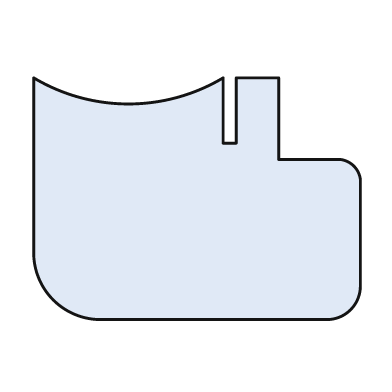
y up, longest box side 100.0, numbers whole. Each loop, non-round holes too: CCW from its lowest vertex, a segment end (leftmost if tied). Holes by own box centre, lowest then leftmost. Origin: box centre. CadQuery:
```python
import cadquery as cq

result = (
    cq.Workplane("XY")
    .moveTo(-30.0, -37.0)
    .lineTo(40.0, -37.0)
    .threePointArc((47.0, -34.0), (50.0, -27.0))
    .lineTo(50.0, 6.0)
    .threePointArc((48.0, 10.0), (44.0, 12.0))
    .lineTo(25.0, 12.0)
    .lineTo(25.0, 37.0)
    .lineTo(12.0, 37.0)
    .lineTo(12.0, 17.0)
    .lineTo(8.0, 17.0)
    .lineTo(8.0, 37.0)
    .threePointArc((-21.0, 29.0), (-50.0, 37.0))
    .lineTo(-50.0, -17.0)
    .threePointArc((-44.0, -31.0), (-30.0, -37.0))
    .close()
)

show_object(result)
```